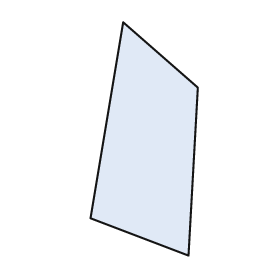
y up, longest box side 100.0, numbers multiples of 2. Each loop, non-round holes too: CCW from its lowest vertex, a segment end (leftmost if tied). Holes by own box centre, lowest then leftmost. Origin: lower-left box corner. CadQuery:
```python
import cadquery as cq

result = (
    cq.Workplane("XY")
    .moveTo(42.0, 0.0)
    .lineTo(46.0, 72.0)
    .lineTo(14.0, 100.0)
    .lineTo(0.0, 16.0)
    .close()
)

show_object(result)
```